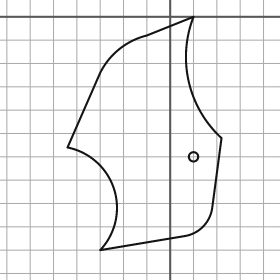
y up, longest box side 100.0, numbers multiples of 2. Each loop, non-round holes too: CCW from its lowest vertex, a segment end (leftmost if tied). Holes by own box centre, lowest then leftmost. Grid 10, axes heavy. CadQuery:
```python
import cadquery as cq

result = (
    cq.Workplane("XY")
    .moveTo(-30.0, -100.0)
    .lineTo(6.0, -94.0)
    .threePointArc((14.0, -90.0), (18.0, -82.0))
    .lineTo(22.0, -52.0)
    .threePointArc((8.0, -28.0), (10.0, 0.0))
    .lineTo(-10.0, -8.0)
    .threePointArc((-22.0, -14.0), (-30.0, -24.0))
    .lineTo(-44.0, -56.0)
    .threePointArc((-24.0, -74.0), (-30.0, -100.0))
    .close()
    .moveTo(10.0, -60.0)
    .circle(2.0)
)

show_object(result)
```